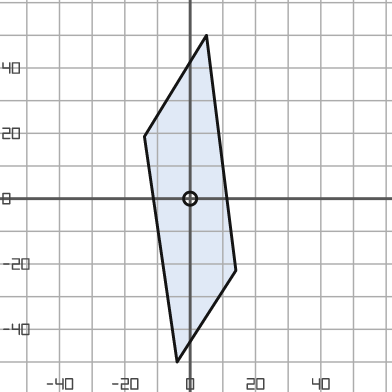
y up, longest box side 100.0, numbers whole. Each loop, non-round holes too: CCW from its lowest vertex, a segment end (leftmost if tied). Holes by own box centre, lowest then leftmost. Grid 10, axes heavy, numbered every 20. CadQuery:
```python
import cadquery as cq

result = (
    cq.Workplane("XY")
    .moveTo(-4.0, -50.0)
    .lineTo(14.0, -22.0)
    .lineTo(5.0, 50.0)
    .lineTo(-14.0, 19.0)
    .close()
    .moveTo(0.0, 0.0)
    .circle(2.0)
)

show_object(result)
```